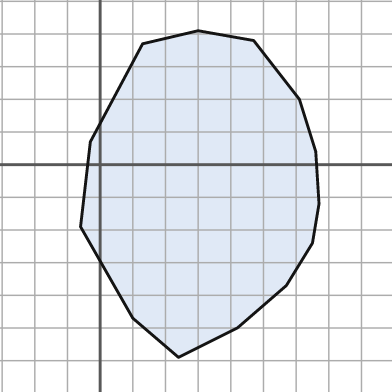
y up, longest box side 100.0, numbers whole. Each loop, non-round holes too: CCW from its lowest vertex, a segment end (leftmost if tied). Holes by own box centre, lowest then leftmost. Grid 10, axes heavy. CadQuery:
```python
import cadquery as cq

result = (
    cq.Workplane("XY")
    .moveTo(24.0, -59.0)
    .lineTo(42.0, -50.0)
    .lineTo(57.0, -37.0)
    .lineTo(65.0, -24.0)
    .lineTo(67.0, -12.0)
    .lineTo(66.0, 4.0)
    .lineTo(61.0, 20.0)
    .lineTo(47.0, 38.0)
    .lineTo(30.0, 41.0)
    .lineTo(13.0, 37.0)
    .lineTo(-3.0, 7.0)
    .lineTo(-6.0, -19.0)
    .lineTo(10.0, -47.0)
    .close()
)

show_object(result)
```